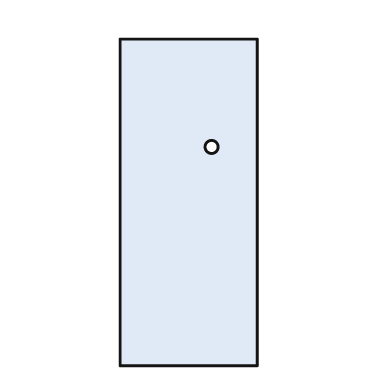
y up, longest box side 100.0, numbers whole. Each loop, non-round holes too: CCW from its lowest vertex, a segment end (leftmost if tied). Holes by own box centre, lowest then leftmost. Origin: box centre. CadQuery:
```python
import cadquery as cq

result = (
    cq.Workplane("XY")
    .moveTo(-21.0, -50.0)
    .lineTo(21.0, -50.0)
    .lineTo(21.0, 50.0)
    .lineTo(-21.0, 50.0)
    .close()
    .moveTo(7.0, 17.0)
    .circle(2.0)
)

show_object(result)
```